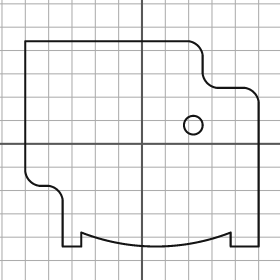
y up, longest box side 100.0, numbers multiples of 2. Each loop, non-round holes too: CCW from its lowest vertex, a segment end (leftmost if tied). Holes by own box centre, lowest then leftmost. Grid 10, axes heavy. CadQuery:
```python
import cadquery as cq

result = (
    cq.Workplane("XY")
    .moveTo(-34.0, -44.0)
    .lineTo(-26.0, -44.0)
    .lineTo(-26.0, -38.0)
    .threePointArc((6.0, -44.0), (38.0, -38.0))
    .lineTo(38.0, -44.0)
    .lineTo(50.0, -44.0)
    .lineTo(50.0, 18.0)
    .threePointArc((48.0, 22.0), (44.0, 24.0))
    .lineTo(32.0, 24.0)
    .threePointArc((28.0, 26.0), (26.0, 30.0))
    .lineTo(26.0, 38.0)
    .threePointArc((24.0, 42.0), (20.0, 44.0))
    .lineTo(-50.0, 44.0)
    .lineTo(-50.0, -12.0)
    .threePointArc((-48.0, -16.0), (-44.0, -18.0))
    .lineTo(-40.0, -18.0)
    .threePointArc((-36.0, -20.0), (-34.0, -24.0))
    .close()
    .moveTo(22.0, 8.0)
    .circle(4.0)
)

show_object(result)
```